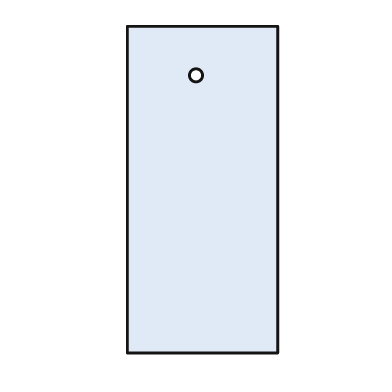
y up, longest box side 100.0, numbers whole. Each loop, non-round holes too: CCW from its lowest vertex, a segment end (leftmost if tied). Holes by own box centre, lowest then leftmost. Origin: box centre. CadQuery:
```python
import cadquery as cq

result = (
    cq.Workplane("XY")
    .moveTo(-23.0, -50.0)
    .lineTo(23.0, -50.0)
    .lineTo(23.0, 50.0)
    .lineTo(-23.0, 50.0)
    .close()
    .moveTo(-2.0, 35.0)
    .circle(2.0)
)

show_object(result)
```